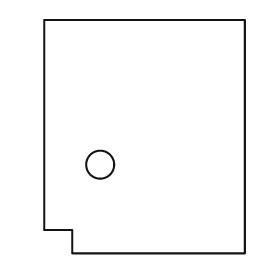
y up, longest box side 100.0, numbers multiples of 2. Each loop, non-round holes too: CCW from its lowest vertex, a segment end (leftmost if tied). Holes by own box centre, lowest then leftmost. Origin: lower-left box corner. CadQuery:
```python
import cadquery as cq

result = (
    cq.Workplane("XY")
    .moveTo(12.0, 0.0)
    .lineTo(86.0, 0.0)
    .lineTo(86.0, 100.0)
    .lineTo(0.0, 100.0)
    .lineTo(0.0, 10.0)
    .lineTo(12.0, 10.0)
    .close()
    .moveTo(24.0, 38.0)
    .circle(6.0)
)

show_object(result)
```